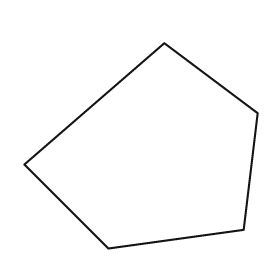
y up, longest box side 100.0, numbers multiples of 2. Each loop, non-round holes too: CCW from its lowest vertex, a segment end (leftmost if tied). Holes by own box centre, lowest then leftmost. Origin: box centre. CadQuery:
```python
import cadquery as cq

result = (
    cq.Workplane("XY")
    .moveTo(-14.0, -44.0)
    .lineTo(44.0, -36.0)
    .lineTo(50.0, 14.0)
    .lineTo(10.0, 44.0)
    .lineTo(-50.0, -8.0)
    .close()
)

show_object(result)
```